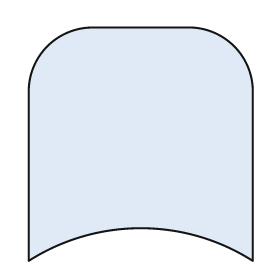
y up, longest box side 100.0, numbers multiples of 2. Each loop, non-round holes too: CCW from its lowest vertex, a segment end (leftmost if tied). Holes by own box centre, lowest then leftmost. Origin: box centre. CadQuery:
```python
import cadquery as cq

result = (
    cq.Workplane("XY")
    .moveTo(-48.0, -50.0)
    .threePointArc((0.0, -36.0), (48.0, -50.0))
    .lineTo(48.0, 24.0)
    .threePointArc((40.0, 42.0), (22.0, 50.0))
    .lineTo(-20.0, 50.0)
    .threePointArc((-40.0, 42.0), (-48.0, 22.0))
    .close()
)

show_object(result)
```